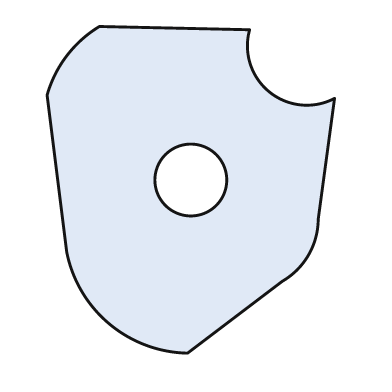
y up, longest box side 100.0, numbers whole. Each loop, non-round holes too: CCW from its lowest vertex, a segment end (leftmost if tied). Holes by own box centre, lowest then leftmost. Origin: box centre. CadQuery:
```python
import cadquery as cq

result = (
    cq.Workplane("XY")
    .moveTo(-1.0, -50.0)
    .lineTo(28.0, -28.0)
    .threePointArc((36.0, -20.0), (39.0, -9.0))
    .lineTo(44.0, 28.0)
    .threePointArc((24.0, 30.0), (18.0, 49.0))
    .lineTo(-28.0, 50.0)
    .threePointArc((-38.0, 41.0), (-44.0, 29.0))
    .lineTo(-38.0, -19.0)
    .threePointArc((-25.0, -41.0), (-1.0, -50.0))
    .close()
    .moveTo(0.0, 3.0)
    .circle(11.0)
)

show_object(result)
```